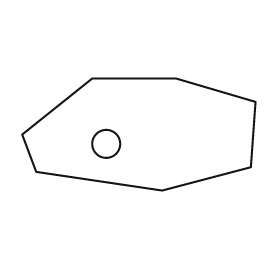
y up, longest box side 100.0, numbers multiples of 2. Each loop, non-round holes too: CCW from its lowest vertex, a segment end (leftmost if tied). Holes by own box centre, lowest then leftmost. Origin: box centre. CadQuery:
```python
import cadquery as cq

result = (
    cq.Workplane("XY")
    .moveTo(10.0, -24.0)
    .lineTo(48.0, -14.0)
    .lineTo(50.0, 14.0)
    .lineTo(16.0, 24.0)
    .lineTo(-20.0, 24.0)
    .lineTo(-50.0, 0.0)
    .lineTo(-44.0, -16.0)
    .close()
    .moveTo(-14.0, -4.0)
    .circle(6.0)
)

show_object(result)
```